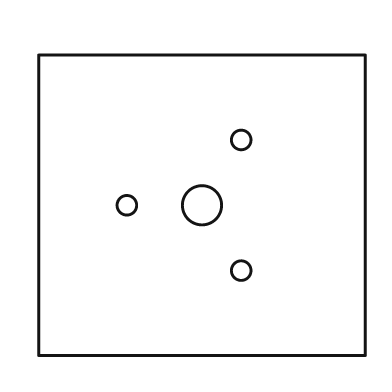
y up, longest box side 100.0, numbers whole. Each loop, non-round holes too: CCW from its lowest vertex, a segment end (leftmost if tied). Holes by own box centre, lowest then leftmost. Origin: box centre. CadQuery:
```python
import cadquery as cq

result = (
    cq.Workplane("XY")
    .moveTo(-50.0, -46.0)
    .lineTo(50.0, -46.0)
    .lineTo(50.0, 46.0)
    .lineTo(-50.0, 46.0)
    .close()
    .moveTo(12.0, -20.0)
    .circle(3.0)
    .moveTo(-23.0, 0.0)
    .circle(3.0)
    .moveTo(0.0, 0.0)
    .circle(6.0)
    .moveTo(12.0, 20.0)
    .circle(3.0)
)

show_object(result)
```